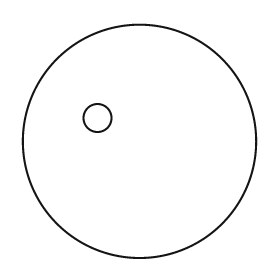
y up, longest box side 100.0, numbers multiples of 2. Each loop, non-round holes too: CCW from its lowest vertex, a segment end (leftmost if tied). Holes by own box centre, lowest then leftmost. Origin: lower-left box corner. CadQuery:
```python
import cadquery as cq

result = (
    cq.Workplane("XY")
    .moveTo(50.0, 50.0)
    .circle(50.0)
    .moveTo(32.0, 60.0)
    .circle(6.0)
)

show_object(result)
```